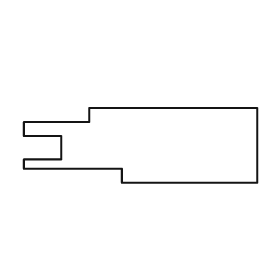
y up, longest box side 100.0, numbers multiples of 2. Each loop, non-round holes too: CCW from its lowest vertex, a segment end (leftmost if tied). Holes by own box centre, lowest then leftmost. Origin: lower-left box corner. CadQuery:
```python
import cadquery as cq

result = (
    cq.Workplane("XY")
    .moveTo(42.0, 0.0)
    .lineTo(100.0, 0.0)
    .lineTo(100.0, 32.0)
    .lineTo(28.0, 32.0)
    .lineTo(28.0, 26.0)
    .lineTo(0.0, 26.0)
    .lineTo(0.0, 20.0)
    .lineTo(16.0, 20.0)
    .lineTo(16.0, 10.0)
    .lineTo(0.0, 10.0)
    .lineTo(0.0, 6.0)
    .lineTo(42.0, 6.0)
    .close()
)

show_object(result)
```